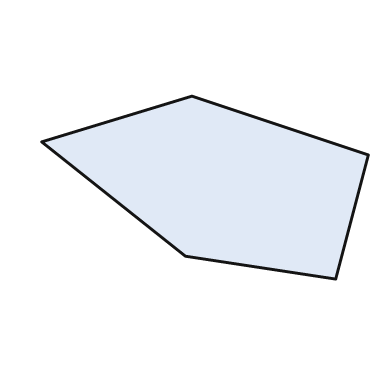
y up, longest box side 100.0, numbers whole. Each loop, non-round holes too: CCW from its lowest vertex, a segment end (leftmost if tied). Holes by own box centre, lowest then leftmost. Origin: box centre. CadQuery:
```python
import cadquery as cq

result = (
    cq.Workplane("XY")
    .moveTo(40.0, -28.0)
    .lineTo(50.0, 10.0)
    .lineTo(-4.0, 28.0)
    .lineTo(-50.0, 14.0)
    .lineTo(-6.0, -21.0)
    .close()
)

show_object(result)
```